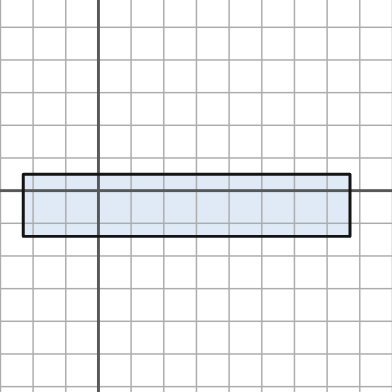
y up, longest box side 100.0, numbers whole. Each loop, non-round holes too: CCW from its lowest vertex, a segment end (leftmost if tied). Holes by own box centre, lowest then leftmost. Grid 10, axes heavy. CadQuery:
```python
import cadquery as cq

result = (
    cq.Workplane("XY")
    .moveTo(-23.0, -14.0)
    .lineTo(77.0, -14.0)
    .lineTo(77.0, 5.0)
    .lineTo(-23.0, 5.0)
    .close()
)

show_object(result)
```